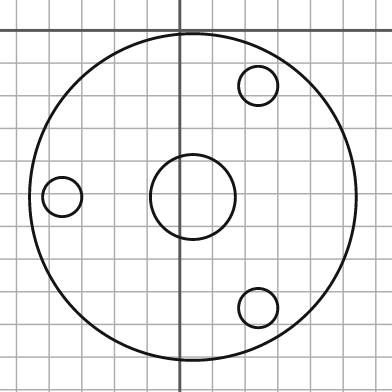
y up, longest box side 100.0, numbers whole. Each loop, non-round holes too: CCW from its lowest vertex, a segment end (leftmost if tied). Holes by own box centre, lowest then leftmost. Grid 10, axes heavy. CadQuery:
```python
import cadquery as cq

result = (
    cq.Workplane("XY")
    .moveTo(4.0, -51.0)
    .circle(50.0)
    .moveTo(24.0, -85.0)
    .circle(6.0)
    .moveTo(-36.0, -51.0)
    .circle(6.0)
    .moveTo(4.0, -51.0)
    .circle(13.0)
    .moveTo(24.0, -17.0)
    .circle(6.0)
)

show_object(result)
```